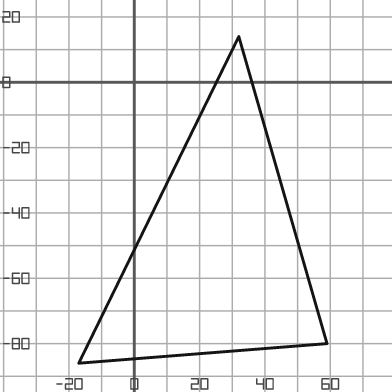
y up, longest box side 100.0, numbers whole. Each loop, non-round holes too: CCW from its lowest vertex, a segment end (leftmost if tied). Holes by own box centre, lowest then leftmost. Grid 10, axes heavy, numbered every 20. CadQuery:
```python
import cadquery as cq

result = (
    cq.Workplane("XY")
    .moveTo(-17.0, -86.0)
    .lineTo(59.0, -80.0)
    .lineTo(32.0, 14.0)
    .close()
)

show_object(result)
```